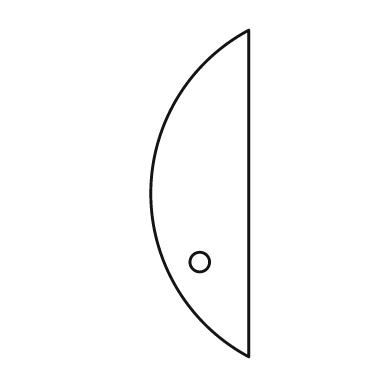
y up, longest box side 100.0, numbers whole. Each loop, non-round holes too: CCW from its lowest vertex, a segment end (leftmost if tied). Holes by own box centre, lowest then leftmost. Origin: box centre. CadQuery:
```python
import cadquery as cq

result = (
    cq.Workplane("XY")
    .moveTo(15.0, -50.0)
    .lineTo(15.0, 50.0)
    .threePointArc((-15.0, 0.0), (15.0, -50.0))
    .close()
    .moveTo(0.0, -21.0)
    .circle(3.0)
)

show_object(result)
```